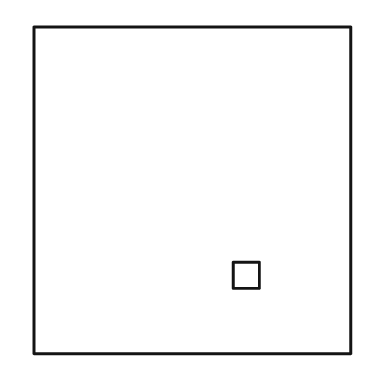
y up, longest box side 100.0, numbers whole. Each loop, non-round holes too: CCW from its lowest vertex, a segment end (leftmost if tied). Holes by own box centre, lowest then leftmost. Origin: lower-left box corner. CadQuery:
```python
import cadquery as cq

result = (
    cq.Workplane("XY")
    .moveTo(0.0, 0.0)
    .lineTo(97.0, 0.0)
    .lineTo(97.0, 100.0)
    .lineTo(0.0, 100.0)
    .close()
    .moveTo(61.0, 20.0)
    .lineTo(69.0, 20.0)
    .lineTo(69.0, 28.0)
    .lineTo(61.0, 28.0)
    .close()
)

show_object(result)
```